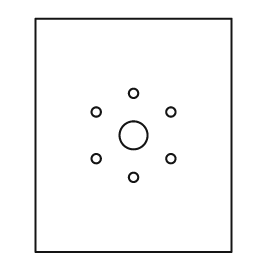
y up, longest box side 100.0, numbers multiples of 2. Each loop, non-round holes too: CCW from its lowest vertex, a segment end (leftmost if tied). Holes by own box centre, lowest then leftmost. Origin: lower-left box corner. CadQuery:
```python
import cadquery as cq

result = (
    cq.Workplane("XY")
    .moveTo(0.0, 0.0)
    .lineTo(84.0, 0.0)
    .lineTo(84.0, 100.0)
    .lineTo(0.0, 100.0)
    .close()
    .moveTo(42.0, 32.0)
    .circle(2.0)
    .moveTo(26.0, 40.0)
    .circle(2.0)
    .moveTo(58.0, 40.0)
    .circle(2.0)
    .moveTo(42.0, 50.0)
    .circle(6.0)
    .moveTo(26.0, 60.0)
    .circle(2.0)
    .moveTo(58.0, 60.0)
    .circle(2.0)
    .moveTo(42.0, 68.0)
    .circle(2.0)
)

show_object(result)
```